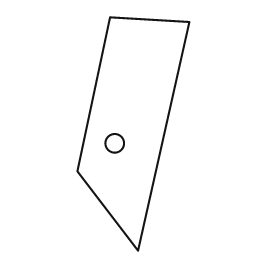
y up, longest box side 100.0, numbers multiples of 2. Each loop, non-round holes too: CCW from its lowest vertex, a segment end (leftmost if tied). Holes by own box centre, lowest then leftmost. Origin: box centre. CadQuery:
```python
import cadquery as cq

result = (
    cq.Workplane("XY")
    .moveTo(2.0, -50.0)
    .lineTo(24.0, 48.0)
    .lineTo(-10.0, 50.0)
    .lineTo(-24.0, -16.0)
    .close()
    .moveTo(-8.0, -4.0)
    .circle(4.0)
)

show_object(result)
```